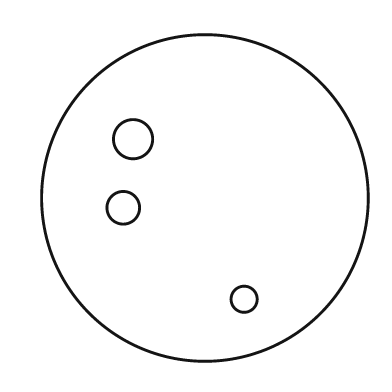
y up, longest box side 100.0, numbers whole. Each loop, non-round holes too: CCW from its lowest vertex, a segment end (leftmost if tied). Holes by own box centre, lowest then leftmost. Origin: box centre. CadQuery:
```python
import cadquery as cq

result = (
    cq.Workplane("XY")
    .moveTo(0.0, 0.0)
    .circle(50.0)
    .moveTo(12.0, -31.0)
    .circle(4.0)
    .moveTo(-25.0, -3.0)
    .circle(5.0)
    .moveTo(-22.0, 18.0)
    .circle(6.0)
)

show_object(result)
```